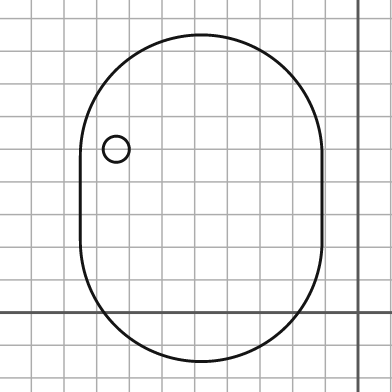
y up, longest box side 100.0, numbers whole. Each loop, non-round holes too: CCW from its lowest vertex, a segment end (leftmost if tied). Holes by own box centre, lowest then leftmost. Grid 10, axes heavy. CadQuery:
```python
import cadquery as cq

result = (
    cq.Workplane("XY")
    .moveTo(-85.0, 22.0)
    .threePointArc((-48.0, -15.0), (-11.0, 22.0))
    .lineTo(-11.0, 48.0)
    .threePointArc((-48.0, 85.0), (-85.0, 48.0))
    .close()
    .moveTo(-74.0, 50.0)
    .circle(4.0)
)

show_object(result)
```